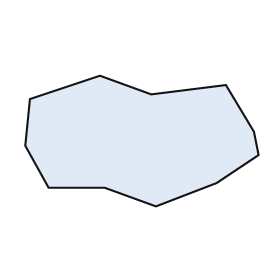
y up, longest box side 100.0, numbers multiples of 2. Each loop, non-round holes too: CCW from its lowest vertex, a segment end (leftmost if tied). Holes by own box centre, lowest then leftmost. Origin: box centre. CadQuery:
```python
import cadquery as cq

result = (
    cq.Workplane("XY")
    .moveTo(6.0, -28.0)
    .lineTo(32.0, -18.0)
    .lineTo(50.0, -6.0)
    .lineTo(48.0, 4.0)
    .lineTo(36.0, 24.0)
    .lineTo(4.0, 20.0)
    .lineTo(-18.0, 28.0)
    .lineTo(-48.0, 18.0)
    .lineTo(-50.0, -2.0)
    .lineTo(-40.0, -20.0)
    .lineTo(-16.0, -20.0)
    .close()
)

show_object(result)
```